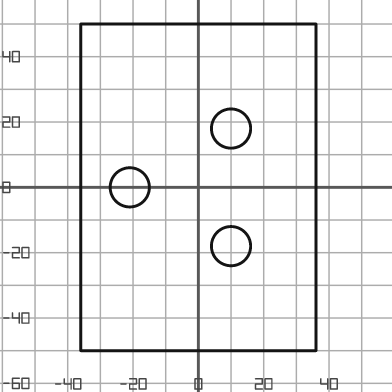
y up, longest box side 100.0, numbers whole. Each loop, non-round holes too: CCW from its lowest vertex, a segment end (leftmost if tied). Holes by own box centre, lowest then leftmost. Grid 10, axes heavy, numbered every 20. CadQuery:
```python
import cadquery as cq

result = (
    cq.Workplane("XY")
    .moveTo(-36.0, -50.0)
    .lineTo(36.0, -50.0)
    .lineTo(36.0, 50.0)
    .lineTo(-36.0, 50.0)
    .close()
    .moveTo(10.0, -18.0)
    .circle(6.0)
    .moveTo(-21.0, 0.0)
    .circle(6.0)
    .moveTo(10.0, 18.0)
    .circle(6.0)
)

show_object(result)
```